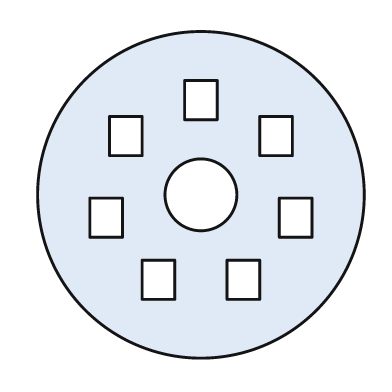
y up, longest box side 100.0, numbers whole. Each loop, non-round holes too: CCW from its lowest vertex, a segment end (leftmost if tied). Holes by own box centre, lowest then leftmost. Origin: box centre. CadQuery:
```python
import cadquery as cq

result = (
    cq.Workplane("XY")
    .moveTo(0.0, 0.0)
    .circle(50.0)
    .moveTo(-18.0, -32.0)
    .lineTo(-8.0, -32.0)
    .lineTo(-8.0, -20.0)
    .lineTo(-18.0, -20.0)
    .close()
    .moveTo(8.0, -32.0)
    .lineTo(18.0, -32.0)
    .lineTo(18.0, -20.0)
    .lineTo(8.0, -20.0)
    .close()
    .moveTo(-34.0, -13.0)
    .lineTo(-24.0, -13.0)
    .lineTo(-24.0, -1.0)
    .lineTo(-34.0, -1.0)
    .close()
    .moveTo(24.0, -13.0)
    .lineTo(34.0, -13.0)
    .lineTo(34.0, -1.0)
    .lineTo(24.0, -1.0)
    .close()
    .moveTo(0.0, 0.0)
    .circle(11.0)
    .moveTo(-28.0, 12.0)
    .lineTo(-18.0, 12.0)
    .lineTo(-18.0, 24.0)
    .lineTo(-28.0, 24.0)
    .close()
    .moveTo(18.0, 12.0)
    .lineTo(28.0, 12.0)
    .lineTo(28.0, 24.0)
    .lineTo(18.0, 24.0)
    .close()
    .moveTo(-5.0, 23.0)
    .lineTo(5.0, 23.0)
    .lineTo(5.0, 35.0)
    .lineTo(-5.0, 35.0)
    .close()
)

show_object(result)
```